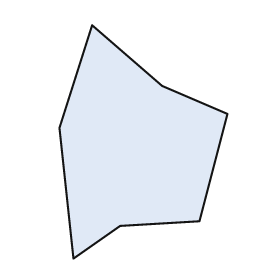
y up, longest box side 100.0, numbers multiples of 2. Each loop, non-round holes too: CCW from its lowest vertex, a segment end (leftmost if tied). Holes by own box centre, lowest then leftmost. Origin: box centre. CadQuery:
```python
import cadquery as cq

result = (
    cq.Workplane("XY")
    .moveTo(-30.0, -50.0)
    .lineTo(-10.0, -36.0)
    .lineTo(24.0, -34.0)
    .lineTo(36.0, 12.0)
    .lineTo(8.0, 24.0)
    .lineTo(-22.0, 50.0)
    .lineTo(-36.0, 6.0)
    .close()
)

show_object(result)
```